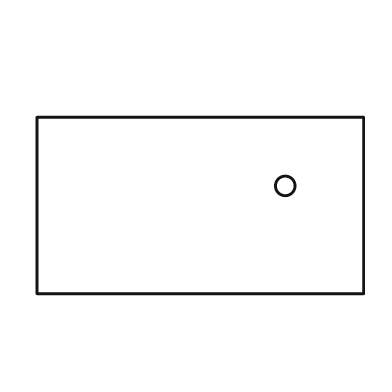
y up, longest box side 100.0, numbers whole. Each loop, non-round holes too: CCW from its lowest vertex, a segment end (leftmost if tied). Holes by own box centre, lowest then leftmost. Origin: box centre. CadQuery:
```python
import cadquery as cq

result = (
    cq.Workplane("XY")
    .moveTo(-50.0, -27.0)
    .lineTo(50.0, -27.0)
    .lineTo(50.0, 27.0)
    .lineTo(-50.0, 27.0)
    .close()
    .moveTo(26.0, 6.0)
    .circle(3.0)
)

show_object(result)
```